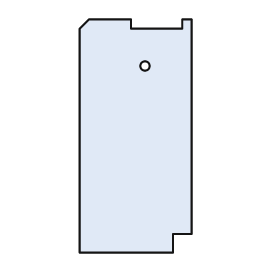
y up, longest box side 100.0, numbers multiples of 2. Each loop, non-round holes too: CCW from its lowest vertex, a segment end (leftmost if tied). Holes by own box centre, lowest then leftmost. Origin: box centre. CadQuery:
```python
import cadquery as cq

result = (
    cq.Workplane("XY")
    .moveTo(-24.0, -50.0)
    .lineTo(16.0, -50.0)
    .lineTo(16.0, -42.0)
    .lineTo(24.0, -42.0)
    .lineTo(24.0, 50.0)
    .lineTo(20.0, 50.0)
    .lineTo(20.0, 46.0)
    .lineTo(-2.0, 46.0)
    .lineTo(-2.0, 50.0)
    .lineTo(-20.0, 50.0)
    .lineTo(-24.0, 46.0)
    .close()
    .moveTo(4.0, 30.0)
    .circle(2.0)
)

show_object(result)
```